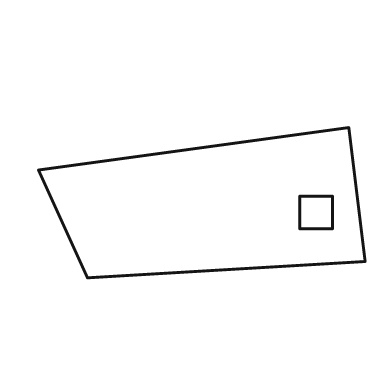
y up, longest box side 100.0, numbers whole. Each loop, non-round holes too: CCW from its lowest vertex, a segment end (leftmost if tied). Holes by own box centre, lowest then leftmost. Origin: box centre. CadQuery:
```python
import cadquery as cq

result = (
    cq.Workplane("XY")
    .moveTo(-35.0, -23.0)
    .lineTo(50.0, -18.0)
    .lineTo(45.0, 23.0)
    .lineTo(-50.0, 10.0)
    .close()
    .moveTo(30.0, -8.0)
    .lineTo(40.0, -8.0)
    .lineTo(40.0, 2.0)
    .lineTo(30.0, 2.0)
    .close()
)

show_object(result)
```